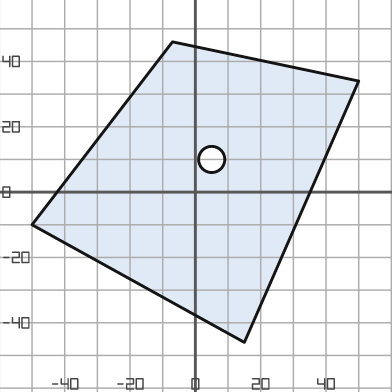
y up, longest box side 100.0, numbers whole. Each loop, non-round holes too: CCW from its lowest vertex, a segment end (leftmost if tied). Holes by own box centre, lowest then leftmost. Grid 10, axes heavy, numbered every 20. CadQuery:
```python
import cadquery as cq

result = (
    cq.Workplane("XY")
    .moveTo(15.0, -46.0)
    .lineTo(50.0, 34.0)
    .lineTo(-7.0, 46.0)
    .lineTo(-50.0, -10.0)
    .close()
    .moveTo(5.0, 10.0)
    .circle(4.0)
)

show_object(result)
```